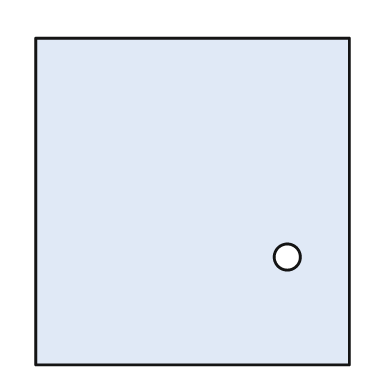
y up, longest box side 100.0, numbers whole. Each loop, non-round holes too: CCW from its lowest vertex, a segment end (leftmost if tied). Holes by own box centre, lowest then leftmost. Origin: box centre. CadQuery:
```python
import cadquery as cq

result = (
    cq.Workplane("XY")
    .moveTo(-48.0, -50.0)
    .lineTo(48.0, -50.0)
    .lineTo(48.0, 50.0)
    .lineTo(-48.0, 50.0)
    .close()
    .moveTo(29.0, -17.0)
    .circle(4.0)
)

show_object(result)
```